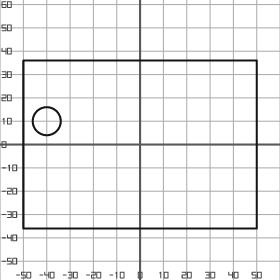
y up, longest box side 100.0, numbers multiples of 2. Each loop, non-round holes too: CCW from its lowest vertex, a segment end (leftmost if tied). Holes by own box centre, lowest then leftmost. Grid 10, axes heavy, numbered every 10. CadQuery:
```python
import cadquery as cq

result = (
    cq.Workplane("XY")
    .moveTo(-50.0, -36.0)
    .lineTo(50.0, -36.0)
    .lineTo(50.0, 36.0)
    .lineTo(-50.0, 36.0)
    .close()
    .moveTo(-40.0, 10.0)
    .circle(6.0)
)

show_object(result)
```